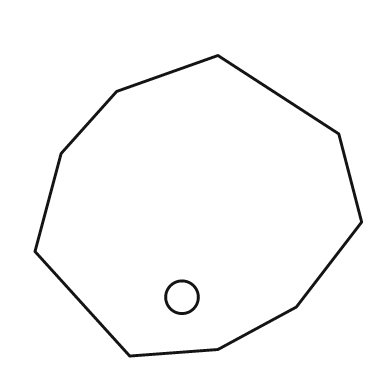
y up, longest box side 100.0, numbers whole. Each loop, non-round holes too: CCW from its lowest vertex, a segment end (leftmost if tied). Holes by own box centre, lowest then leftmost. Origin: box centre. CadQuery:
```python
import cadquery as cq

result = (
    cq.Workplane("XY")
    .moveTo(-21.0, -46.0)
    .lineTo(6.0, -44.0)
    .lineTo(30.0, -31.0)
    .lineTo(50.0, -5.0)
    .lineTo(43.0, 22.0)
    .lineTo(6.0, 46.0)
    .lineTo(-25.0, 35.0)
    .lineTo(-42.0, 16.0)
    .lineTo(-50.0, -14.0)
    .close()
    .moveTo(-5.0, -28.0)
    .circle(5.0)
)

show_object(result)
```